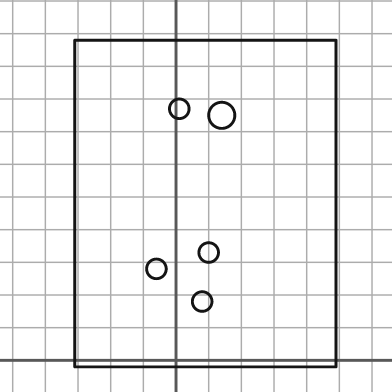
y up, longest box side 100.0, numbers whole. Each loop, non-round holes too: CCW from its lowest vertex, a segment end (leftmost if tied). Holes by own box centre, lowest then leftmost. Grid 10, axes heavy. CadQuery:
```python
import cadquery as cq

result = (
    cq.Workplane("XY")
    .moveTo(-31.0, -2.0)
    .lineTo(49.0, -2.0)
    .lineTo(49.0, 98.0)
    .lineTo(-31.0, 98.0)
    .close()
    .moveTo(8.0, 18.0)
    .circle(3.0)
    .moveTo(-6.0, 28.0)
    .circle(3.0)
    .moveTo(10.0, 33.0)
    .circle(3.0)
    .moveTo(14.0, 75.0)
    .circle(4.0)
    .moveTo(1.0, 77.0)
    .circle(3.0)
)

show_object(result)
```